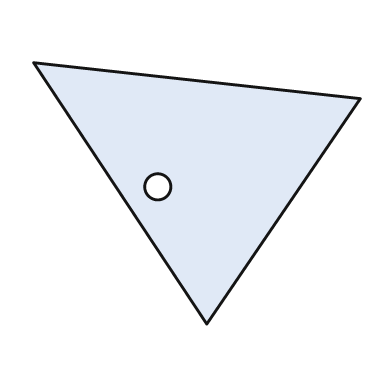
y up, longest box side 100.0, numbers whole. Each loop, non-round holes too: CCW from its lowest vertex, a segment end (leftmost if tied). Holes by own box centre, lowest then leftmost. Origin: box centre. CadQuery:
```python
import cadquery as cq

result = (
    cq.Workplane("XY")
    .moveTo(3.0, -40.0)
    .lineTo(50.0, 29.0)
    .lineTo(-50.0, 40.0)
    .close()
    .moveTo(-12.0, 2.0)
    .circle(4.0)
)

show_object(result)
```